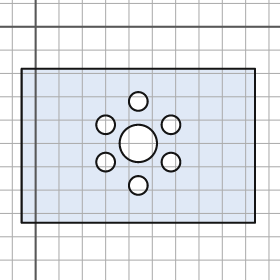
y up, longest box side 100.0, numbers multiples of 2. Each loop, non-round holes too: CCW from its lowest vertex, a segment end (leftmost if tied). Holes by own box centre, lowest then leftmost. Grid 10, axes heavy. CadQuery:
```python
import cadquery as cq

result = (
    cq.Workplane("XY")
    .moveTo(-6.0, -84.0)
    .lineTo(94.0, -84.0)
    .lineTo(94.0, -18.0)
    .lineTo(-6.0, -18.0)
    .close()
    .moveTo(44.0, -68.0)
    .circle(4.0)
    .moveTo(30.0, -58.0)
    .circle(4.0)
    .moveTo(58.0, -58.0)
    .circle(4.0)
    .moveTo(44.0, -50.0)
    .circle(8.0)
    .moveTo(30.0, -42.0)
    .circle(4.0)
    .moveTo(58.0, -42.0)
    .circle(4.0)
    .moveTo(44.0, -32.0)
    .circle(4.0)
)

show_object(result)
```